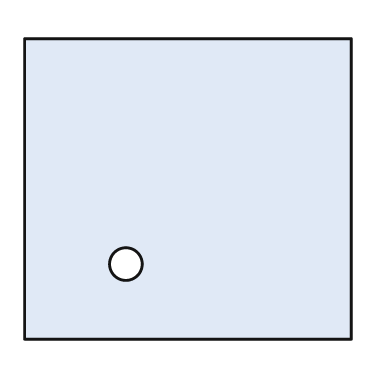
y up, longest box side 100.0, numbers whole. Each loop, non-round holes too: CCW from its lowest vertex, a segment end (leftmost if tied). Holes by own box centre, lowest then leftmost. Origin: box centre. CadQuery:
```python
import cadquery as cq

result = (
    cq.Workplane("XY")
    .moveTo(-50.0, -46.0)
    .lineTo(50.0, -46.0)
    .lineTo(50.0, 46.0)
    .lineTo(-50.0, 46.0)
    .close()
    .moveTo(-19.0, -23.0)
    .circle(5.0)
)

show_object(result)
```